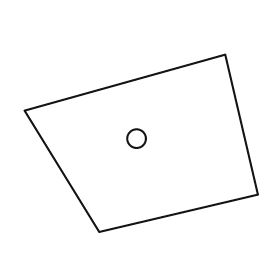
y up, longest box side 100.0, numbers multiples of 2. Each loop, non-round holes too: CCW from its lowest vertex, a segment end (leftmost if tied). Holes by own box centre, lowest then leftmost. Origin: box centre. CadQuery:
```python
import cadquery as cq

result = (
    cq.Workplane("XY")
    .moveTo(-18.0, -38.0)
    .lineTo(50.0, -22.0)
    .lineTo(36.0, 38.0)
    .lineTo(-50.0, 14.0)
    .close()
    .moveTo(-2.0, 2.0)
    .circle(4.0)
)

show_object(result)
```